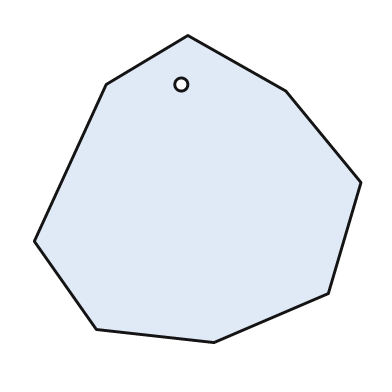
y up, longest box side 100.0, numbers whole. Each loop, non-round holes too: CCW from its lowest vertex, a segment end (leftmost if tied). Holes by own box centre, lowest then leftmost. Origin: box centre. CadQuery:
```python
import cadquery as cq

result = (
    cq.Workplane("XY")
    .moveTo(5.0, -47.0)
    .lineTo(40.0, -32.0)
    .lineTo(50.0, 2.0)
    .lineTo(27.0, 30.0)
    .lineTo(-3.0, 47.0)
    .lineTo(-28.0, 32.0)
    .lineTo(-50.0, -16.0)
    .lineTo(-31.0, -43.0)
    .close()
    .moveTo(-5.0, 32.0)
    .circle(2.0)
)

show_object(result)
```